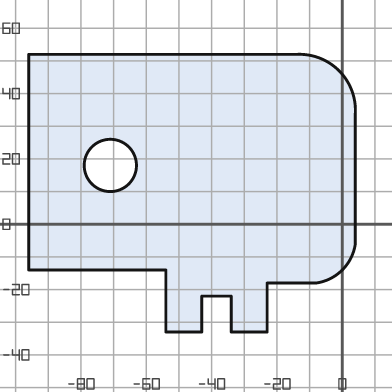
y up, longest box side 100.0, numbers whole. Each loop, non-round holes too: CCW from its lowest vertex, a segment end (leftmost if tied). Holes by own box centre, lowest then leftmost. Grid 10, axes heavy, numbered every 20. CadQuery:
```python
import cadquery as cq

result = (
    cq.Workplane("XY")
    .moveTo(-54.0, -33.0)
    .lineTo(-43.0, -33.0)
    .lineTo(-43.0, -22.0)
    .lineTo(-34.0, -22.0)
    .lineTo(-34.0, -33.0)
    .lineTo(-23.0, -33.0)
    .lineTo(-23.0, -18.0)
    .lineTo(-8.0, -18.0)
    .threePointArc((0.0, -14.0), (4.0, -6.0))
    .lineTo(4.0, 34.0)
    .threePointArc((-1.0, 47.0), (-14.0, 52.0))
    .lineTo(-96.0, 52.0)
    .lineTo(-96.0, -14.0)
    .lineTo(-54.0, -14.0)
    .close()
    .moveTo(-71.0, 18.0)
    .circle(8.0)
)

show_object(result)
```